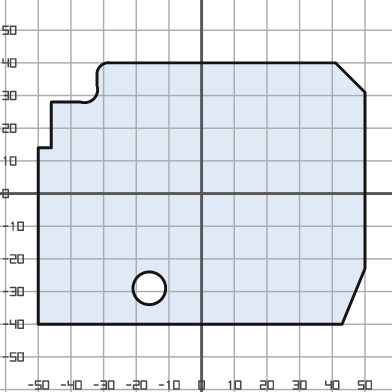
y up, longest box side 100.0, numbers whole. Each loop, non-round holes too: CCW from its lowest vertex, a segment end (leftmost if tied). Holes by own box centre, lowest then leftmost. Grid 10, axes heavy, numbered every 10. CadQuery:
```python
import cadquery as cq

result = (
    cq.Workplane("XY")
    .moveTo(-50.0, -40.0)
    .lineTo(43.0, -40.0)
    .lineTo(50.0, -23.0)
    .lineTo(50.0, 31.0)
    .lineTo(41.0, 40.0)
    .lineTo(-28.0, 40.0)
    .threePointArc((-31.0, 39.0), (-32.0, 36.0))
    .lineTo(-32.0, 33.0)
    .threePointArc((-33.0, 29.0), (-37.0, 28.0))
    .lineTo(-46.0, 28.0)
    .lineTo(-46.0, 14.0)
    .lineTo(-50.0, 14.0)
    .close()
    .moveTo(-16.0, -29.0)
    .circle(5.0)
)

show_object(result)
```